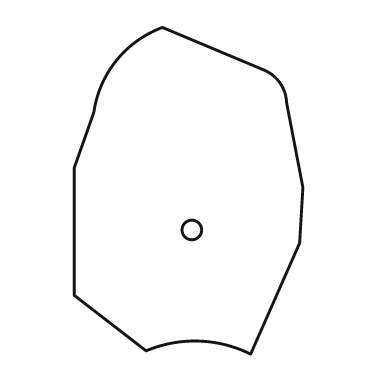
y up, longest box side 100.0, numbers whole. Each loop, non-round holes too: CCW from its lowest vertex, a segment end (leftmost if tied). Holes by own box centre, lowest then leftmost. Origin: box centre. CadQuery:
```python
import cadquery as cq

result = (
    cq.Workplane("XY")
    .moveTo(19.0, -50.0)
    .lineTo(34.0, -16.0)
    .lineTo(35.0, 1.0)
    .lineTo(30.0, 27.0)
    .threePointArc((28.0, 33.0), (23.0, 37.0))
    .lineTo(-8.0, 50.0)
    .threePointArc((-22.0, 40.0), (-29.0, 24.0))
    .lineTo(-35.0, 7.0)
    .lineTo(-35.0, -32.0)
    .lineTo(-13.0, -49.0)
    .threePointArc((3.0, -46.0), (19.0, -50.0))
    .close()
    .moveTo(1.0, -12.0)
    .circle(3.0)
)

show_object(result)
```